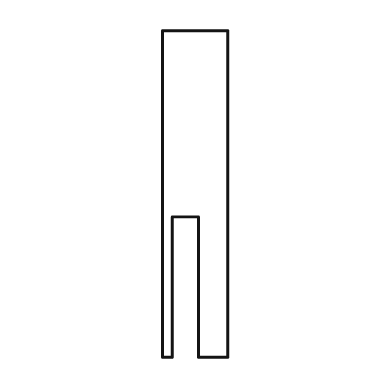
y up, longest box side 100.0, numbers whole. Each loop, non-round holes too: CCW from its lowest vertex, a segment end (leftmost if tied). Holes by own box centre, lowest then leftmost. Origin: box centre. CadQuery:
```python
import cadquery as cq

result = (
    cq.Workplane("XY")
    .moveTo(-10.0, -50.0)
    .lineTo(-7.0, -50.0)
    .lineTo(-7.0, -7.0)
    .lineTo(1.0, -7.0)
    .lineTo(1.0, -50.0)
    .lineTo(10.0, -50.0)
    .lineTo(10.0, 50.0)
    .lineTo(-10.0, 50.0)
    .close()
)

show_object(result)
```